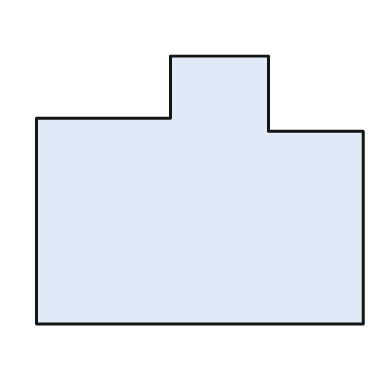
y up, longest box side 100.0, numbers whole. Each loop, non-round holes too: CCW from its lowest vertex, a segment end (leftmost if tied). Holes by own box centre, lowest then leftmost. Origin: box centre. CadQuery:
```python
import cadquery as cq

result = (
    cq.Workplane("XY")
    .moveTo(-50.0, -41.0)
    .lineTo(50.0, -41.0)
    .lineTo(50.0, 18.0)
    .lineTo(21.0, 18.0)
    .lineTo(21.0, 41.0)
    .lineTo(-9.0, 41.0)
    .lineTo(-9.0, 22.0)
    .lineTo(-50.0, 22.0)
    .close()
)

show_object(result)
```